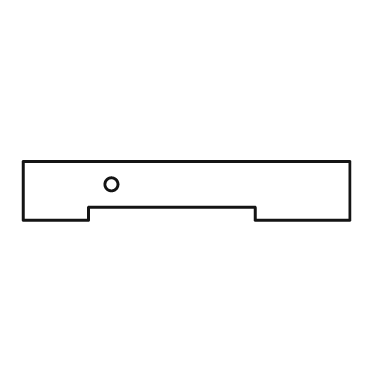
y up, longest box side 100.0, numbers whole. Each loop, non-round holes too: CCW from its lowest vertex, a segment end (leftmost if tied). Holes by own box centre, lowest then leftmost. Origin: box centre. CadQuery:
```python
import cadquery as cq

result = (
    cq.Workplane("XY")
    .moveTo(-50.0, -9.0)
    .lineTo(-30.0, -9.0)
    .lineTo(-30.0, -5.0)
    .lineTo(21.0, -5.0)
    .lineTo(21.0, -9.0)
    .lineTo(50.0, -9.0)
    .lineTo(50.0, 9.0)
    .lineTo(-50.0, 9.0)
    .close()
    .moveTo(-23.0, 2.0)
    .circle(2.0)
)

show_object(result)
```